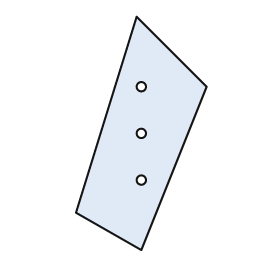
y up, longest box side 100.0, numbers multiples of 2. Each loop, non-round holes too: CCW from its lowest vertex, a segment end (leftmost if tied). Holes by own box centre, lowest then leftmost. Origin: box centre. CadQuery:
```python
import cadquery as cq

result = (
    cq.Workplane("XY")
    .moveTo(0.0, -50.0)
    .lineTo(28.0, 20.0)
    .lineTo(-2.0, 50.0)
    .lineTo(-28.0, -34.0)
    .close()
    .moveTo(0.0, -20.0)
    .circle(2.0)
    .moveTo(0.0, 0.0)
    .circle(2.0)
    .moveTo(0.0, 20.0)
    .circle(2.0)
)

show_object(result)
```